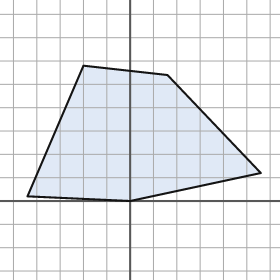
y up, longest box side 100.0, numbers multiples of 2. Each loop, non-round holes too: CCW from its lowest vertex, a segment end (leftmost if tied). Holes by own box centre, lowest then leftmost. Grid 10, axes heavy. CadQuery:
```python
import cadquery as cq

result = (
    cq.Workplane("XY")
    .moveTo(0.0, 0.0)
    .lineTo(56.0, 12.0)
    .lineTo(16.0, 54.0)
    .lineTo(-20.0, 58.0)
    .lineTo(-44.0, 2.0)
    .close()
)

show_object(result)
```